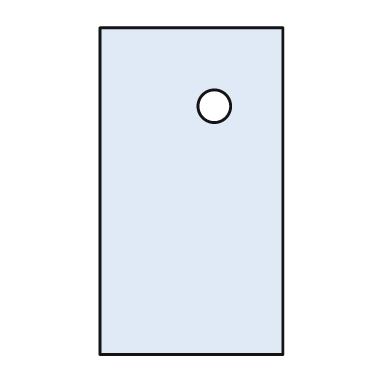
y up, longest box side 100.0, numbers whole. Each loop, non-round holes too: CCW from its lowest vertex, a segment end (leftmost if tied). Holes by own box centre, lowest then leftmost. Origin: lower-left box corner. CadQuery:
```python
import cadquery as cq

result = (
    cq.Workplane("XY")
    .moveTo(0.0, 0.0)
    .lineTo(56.0, 0.0)
    .lineTo(56.0, 100.0)
    .lineTo(0.0, 100.0)
    .close()
    .moveTo(35.0, 76.0)
    .circle(5.0)
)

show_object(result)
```